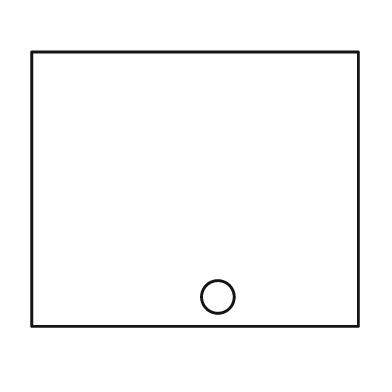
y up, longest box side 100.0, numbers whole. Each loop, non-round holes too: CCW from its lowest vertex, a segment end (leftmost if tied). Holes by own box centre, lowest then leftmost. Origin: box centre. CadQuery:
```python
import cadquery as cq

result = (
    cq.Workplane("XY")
    .moveTo(-50.0, -42.0)
    .lineTo(50.0, -42.0)
    .lineTo(50.0, 42.0)
    .lineTo(-50.0, 42.0)
    .close()
    .moveTo(7.0, -33.0)
    .circle(5.0)
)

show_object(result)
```